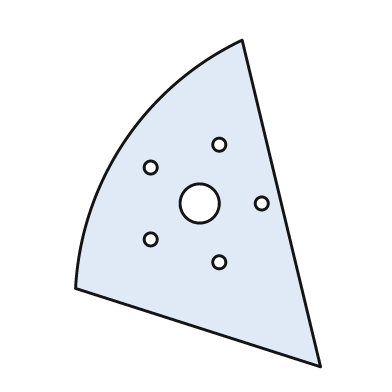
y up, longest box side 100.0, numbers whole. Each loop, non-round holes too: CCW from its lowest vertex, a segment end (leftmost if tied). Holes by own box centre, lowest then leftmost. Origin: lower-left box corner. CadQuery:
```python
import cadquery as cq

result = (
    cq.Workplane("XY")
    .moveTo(75.0, 0.0)
    .lineTo(51.0, 100.0)
    .threePointArc((15.0, 69.0), (0.0, 24.0))
    .close()
    .moveTo(44.0, 32.0)
    .circle(2.0)
    .moveTo(23.0, 39.0)
    .circle(2.0)
    .moveTo(38.0, 50.0)
    .circle(6.0)
    .moveTo(57.0, 50.0)
    .circle(2.0)
    .moveTo(23.0, 61.0)
    .circle(2.0)
    .moveTo(44.0, 68.0)
    .circle(2.0)
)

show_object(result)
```